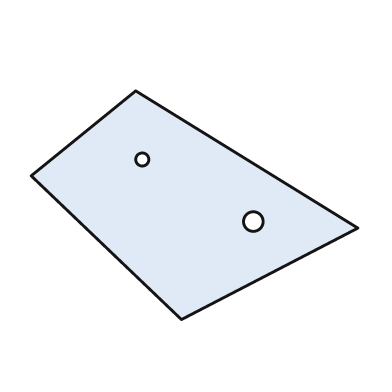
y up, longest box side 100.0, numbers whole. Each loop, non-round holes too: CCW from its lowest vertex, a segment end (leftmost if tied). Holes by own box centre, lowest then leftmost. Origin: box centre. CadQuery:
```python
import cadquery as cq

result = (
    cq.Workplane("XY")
    .moveTo(-4.0, -35.0)
    .lineTo(50.0, -7.0)
    .lineTo(-18.0, 35.0)
    .lineTo(-50.0, 9.0)
    .close()
    .moveTo(18.0, -5.0)
    .circle(3.0)
    .moveTo(-16.0, 14.0)
    .circle(2.0)
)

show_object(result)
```